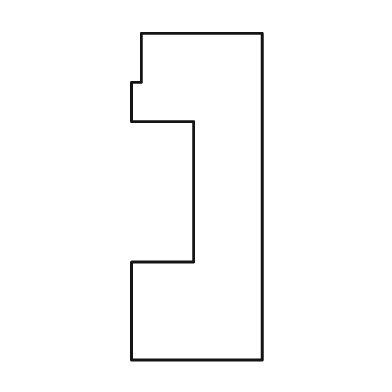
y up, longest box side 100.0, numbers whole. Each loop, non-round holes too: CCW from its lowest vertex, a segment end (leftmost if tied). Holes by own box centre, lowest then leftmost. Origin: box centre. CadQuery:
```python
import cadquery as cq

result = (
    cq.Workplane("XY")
    .moveTo(-20.0, -50.0)
    .lineTo(20.0, -50.0)
    .lineTo(20.0, 50.0)
    .lineTo(-17.0, 50.0)
    .lineTo(-17.0, 35.0)
    .lineTo(-20.0, 35.0)
    .lineTo(-20.0, 23.0)
    .lineTo(-1.0, 23.0)
    .lineTo(-1.0, -20.0)
    .lineTo(-20.0, -20.0)
    .close()
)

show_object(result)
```